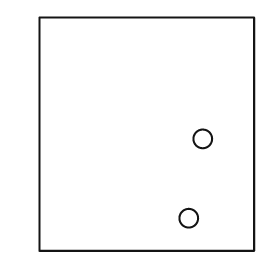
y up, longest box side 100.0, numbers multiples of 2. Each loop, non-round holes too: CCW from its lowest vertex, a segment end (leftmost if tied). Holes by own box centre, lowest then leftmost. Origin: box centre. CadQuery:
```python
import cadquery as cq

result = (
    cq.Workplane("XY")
    .moveTo(-46.0, -50.0)
    .lineTo(46.0, -50.0)
    .lineTo(46.0, 50.0)
    .lineTo(-46.0, 50.0)
    .close()
    .moveTo(18.0, -36.0)
    .circle(4.0)
    .moveTo(24.0, -2.0)
    .circle(4.0)
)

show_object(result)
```